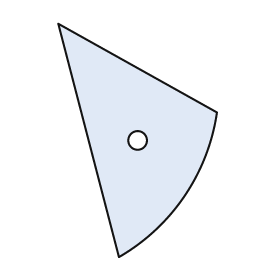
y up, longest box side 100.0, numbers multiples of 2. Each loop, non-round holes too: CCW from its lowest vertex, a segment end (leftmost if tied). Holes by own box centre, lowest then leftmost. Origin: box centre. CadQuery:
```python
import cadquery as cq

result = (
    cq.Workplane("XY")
    .moveTo(-8.0, -50.0)
    .threePointArc((20.0, -24.0), (34.0, 12.0))
    .lineTo(-34.0, 50.0)
    .close()
    .moveTo(0.0, 0.0)
    .circle(4.0)
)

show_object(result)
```